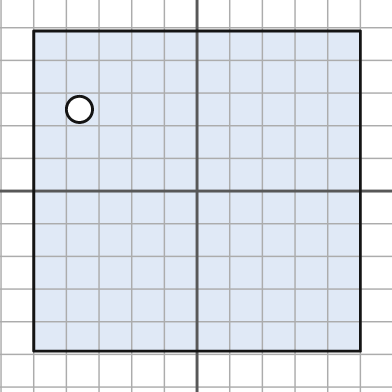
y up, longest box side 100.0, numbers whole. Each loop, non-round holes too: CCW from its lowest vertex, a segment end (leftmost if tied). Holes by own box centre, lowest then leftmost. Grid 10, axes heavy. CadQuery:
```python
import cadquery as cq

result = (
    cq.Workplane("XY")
    .moveTo(-50.0, -49.0)
    .lineTo(50.0, -49.0)
    .lineTo(50.0, 49.0)
    .lineTo(-50.0, 49.0)
    .close()
    .moveTo(-36.0, 25.0)
    .circle(4.0)
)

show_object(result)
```